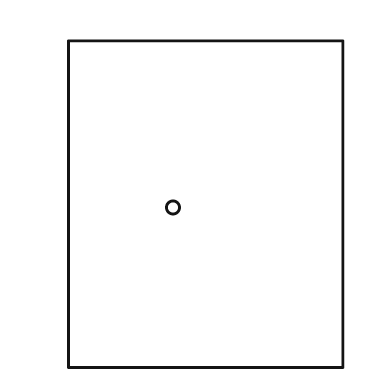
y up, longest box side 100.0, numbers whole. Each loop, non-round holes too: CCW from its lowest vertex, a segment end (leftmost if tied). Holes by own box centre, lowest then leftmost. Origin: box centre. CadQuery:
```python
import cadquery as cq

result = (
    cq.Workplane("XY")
    .moveTo(-42.0, -50.0)
    .lineTo(42.0, -50.0)
    .lineTo(42.0, 50.0)
    .lineTo(-42.0, 50.0)
    .close()
    .moveTo(-10.0, -1.0)
    .circle(2.0)
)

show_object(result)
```